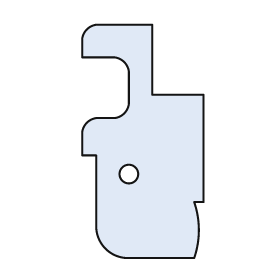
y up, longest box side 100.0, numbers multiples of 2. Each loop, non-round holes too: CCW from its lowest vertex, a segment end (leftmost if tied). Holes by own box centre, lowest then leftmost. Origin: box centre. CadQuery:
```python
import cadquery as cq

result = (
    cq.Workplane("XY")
    .moveTo(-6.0, -50.0)
    .lineTo(22.0, -50.0)
    .threePointArc((24.0, -38.0), (22.0, -26.0))
    .lineTo(26.0, -26.0)
    .lineTo(26.0, 20.0)
    .lineTo(4.0, 20.0)
    .lineTo(4.0, 50.0)
    .lineTo(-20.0, 50.0)
    .threePointArc((-24.0, 48.0), (-26.0, 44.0))
    .lineTo(-26.0, 36.0)
    .lineTo(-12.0, 36.0)
    .threePointArc((-8.0, 34.0), (-6.0, 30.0))
    .lineTo(-6.0, 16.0)
    .threePointArc((-8.0, 12.0), (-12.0, 10.0))
    .lineTo(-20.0, 10.0)
    .threePointArc((-24.0, 8.0), (-26.0, 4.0))
    .lineTo(-26.0, -6.0)
    .lineTo(-20.0, -6.0)
    .lineTo(-20.0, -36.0)
    .threePointArc((-16.0, -46.0), (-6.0, -50.0))
    .close()
    .moveTo(-6.0, -14.0)
    .circle(4.0)
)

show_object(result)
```